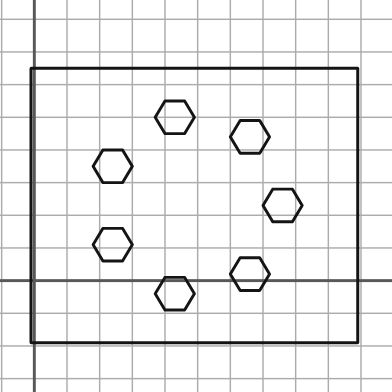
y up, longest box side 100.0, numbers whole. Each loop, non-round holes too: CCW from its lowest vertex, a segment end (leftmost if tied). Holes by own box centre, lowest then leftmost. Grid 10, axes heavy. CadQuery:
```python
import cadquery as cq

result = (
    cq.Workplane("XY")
    .moveTo(-1.0, -19.0)
    .lineTo(99.0, -19.0)
    .lineTo(99.0, 65.0)
    .lineTo(-1.0, 65.0)
    .close()
    .moveTo(40.0, -9.0)
    .lineTo(46.0, -9.0)
    .lineTo(49.0, -4.0)
    .lineTo(46.0, 1.0)
    .lineTo(40.0, 1.0)
    .lineTo(37.0, -4.0)
    .close()
    .moveTo(63.0, -3.0)
    .lineTo(69.0, -3.0)
    .lineTo(72.0, 2.0)
    .lineTo(69.0, 7.0)
    .lineTo(63.0, 7.0)
    .lineTo(60.0, 2.0)
    .close()
    .moveTo(21.0, 6.0)
    .lineTo(27.0, 6.0)
    .lineTo(30.0, 11.0)
    .lineTo(27.0, 16.0)
    .lineTo(21.0, 16.0)
    .lineTo(18.0, 11.0)
    .close()
    .moveTo(73.0, 18.0)
    .lineTo(79.0, 18.0)
    .lineTo(82.0, 23.0)
    .lineTo(79.0, 28.0)
    .lineTo(73.0, 28.0)
    .lineTo(70.0, 23.0)
    .close()
    .moveTo(21.0, 30.0)
    .lineTo(27.0, 30.0)
    .lineTo(30.0, 35.0)
    .lineTo(27.0, 40.0)
    .lineTo(21.0, 40.0)
    .lineTo(18.0, 35.0)
    .close()
    .moveTo(63.0, 39.0)
    .lineTo(69.0, 39.0)
    .lineTo(72.0, 44.0)
    .lineTo(69.0, 49.0)
    .lineTo(63.0, 49.0)
    .lineTo(60.0, 44.0)
    .close()
    .moveTo(40.0, 45.0)
    .lineTo(46.0, 45.0)
    .lineTo(49.0, 50.0)
    .lineTo(46.0, 55.0)
    .lineTo(40.0, 55.0)
    .lineTo(37.0, 50.0)
    .close()
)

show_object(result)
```